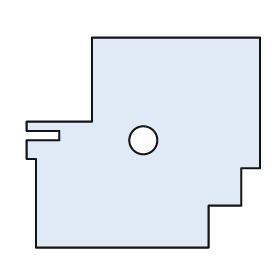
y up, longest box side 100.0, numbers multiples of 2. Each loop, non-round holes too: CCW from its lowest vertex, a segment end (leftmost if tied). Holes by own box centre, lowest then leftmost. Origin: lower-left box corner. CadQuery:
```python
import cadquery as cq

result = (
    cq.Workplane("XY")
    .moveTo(4.0, 0.0)
    .lineTo(78.0, 0.0)
    .lineTo(78.0, 18.0)
    .lineTo(92.0, 18.0)
    .lineTo(92.0, 34.0)
    .lineTo(100.0, 34.0)
    .lineTo(100.0, 90.0)
    .lineTo(28.0, 90.0)
    .lineTo(28.0, 54.0)
    .lineTo(0.0, 54.0)
    .lineTo(0.0, 50.0)
    .lineTo(14.0, 50.0)
    .lineTo(14.0, 46.0)
    .lineTo(0.0, 46.0)
    .lineTo(0.0, 38.0)
    .lineTo(4.0, 38.0)
    .close()
    .moveTo(50.0, 46.0)
    .circle(6.0)
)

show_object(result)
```